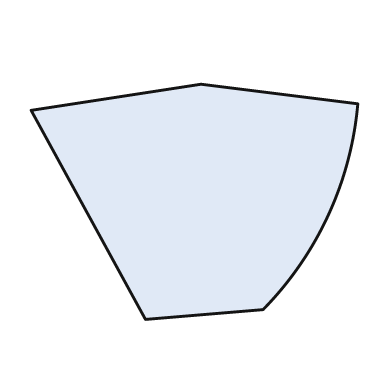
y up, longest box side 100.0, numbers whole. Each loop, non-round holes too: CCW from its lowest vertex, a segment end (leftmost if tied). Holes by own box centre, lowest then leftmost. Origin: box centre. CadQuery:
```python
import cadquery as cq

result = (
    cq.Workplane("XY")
    .moveTo(-15.0, -36.0)
    .lineTo(21.0, -33.0)
    .threePointArc((41.0, -4.0), (50.0, 30.0))
    .lineTo(2.0, 36.0)
    .lineTo(-50.0, 28.0)
    .close()
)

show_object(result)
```